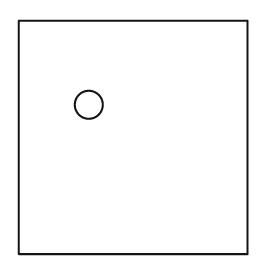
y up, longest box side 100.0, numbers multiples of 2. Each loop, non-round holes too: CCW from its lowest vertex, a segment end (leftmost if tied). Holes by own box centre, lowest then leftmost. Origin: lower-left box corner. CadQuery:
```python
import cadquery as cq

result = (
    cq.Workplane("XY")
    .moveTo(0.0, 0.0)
    .lineTo(98.0, 0.0)
    .lineTo(98.0, 100.0)
    .lineTo(0.0, 100.0)
    .close()
    .moveTo(30.0, 64.0)
    .circle(6.0)
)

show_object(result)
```